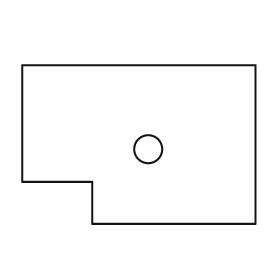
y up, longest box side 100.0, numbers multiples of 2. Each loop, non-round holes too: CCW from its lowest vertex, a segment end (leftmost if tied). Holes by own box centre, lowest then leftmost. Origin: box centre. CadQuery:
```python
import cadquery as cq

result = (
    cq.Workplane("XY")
    .moveTo(-20.0, -34.0)
    .lineTo(50.0, -34.0)
    .lineTo(50.0, 34.0)
    .lineTo(-50.0, 34.0)
    .lineTo(-50.0, -16.0)
    .lineTo(-20.0, -16.0)
    .close()
    .moveTo(4.0, -2.0)
    .circle(6.0)
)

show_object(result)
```